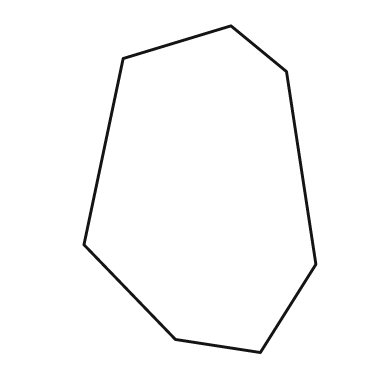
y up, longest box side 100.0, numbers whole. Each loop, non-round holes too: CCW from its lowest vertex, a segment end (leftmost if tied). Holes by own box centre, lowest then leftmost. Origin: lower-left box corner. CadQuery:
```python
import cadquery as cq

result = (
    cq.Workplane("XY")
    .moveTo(54.0, 0.0)
    .lineTo(71.0, 27.0)
    .lineTo(62.0, 86.0)
    .lineTo(45.0, 100.0)
    .lineTo(12.0, 90.0)
    .lineTo(0.0, 33.0)
    .lineTo(28.0, 4.0)
    .close()
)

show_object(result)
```